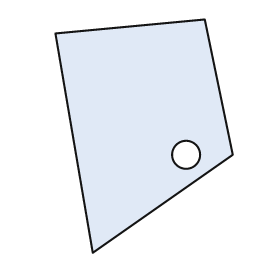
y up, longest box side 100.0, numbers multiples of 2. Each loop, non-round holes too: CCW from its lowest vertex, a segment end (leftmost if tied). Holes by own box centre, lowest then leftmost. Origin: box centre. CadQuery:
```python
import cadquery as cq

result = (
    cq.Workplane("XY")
    .moveTo(-22.0, -50.0)
    .lineTo(38.0, -8.0)
    .lineTo(26.0, 50.0)
    .lineTo(-38.0, 44.0)
    .close()
    .moveTo(18.0, -8.0)
    .circle(6.0)
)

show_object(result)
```